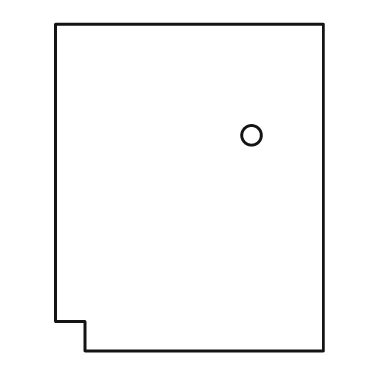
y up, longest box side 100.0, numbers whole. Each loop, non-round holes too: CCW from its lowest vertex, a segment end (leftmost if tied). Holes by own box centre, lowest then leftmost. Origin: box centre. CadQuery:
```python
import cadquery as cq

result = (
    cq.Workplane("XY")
    .moveTo(-32.0, -50.0)
    .lineTo(41.0, -50.0)
    .lineTo(41.0, 50.0)
    .lineTo(-41.0, 50.0)
    .lineTo(-41.0, -41.0)
    .lineTo(-32.0, -41.0)
    .close()
    .moveTo(19.0, 16.0)
    .circle(3.0)
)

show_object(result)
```